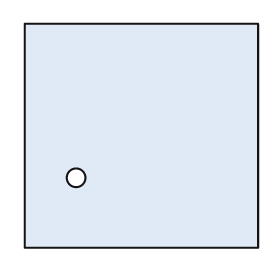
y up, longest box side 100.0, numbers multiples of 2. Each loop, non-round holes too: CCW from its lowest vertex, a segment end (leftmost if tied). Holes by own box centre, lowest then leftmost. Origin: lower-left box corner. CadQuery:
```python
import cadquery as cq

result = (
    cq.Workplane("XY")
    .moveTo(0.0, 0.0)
    .lineTo(100.0, 0.0)
    .lineTo(100.0, 96.0)
    .lineTo(0.0, 96.0)
    .close()
    .moveTo(22.0, 30.0)
    .circle(4.0)
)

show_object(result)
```